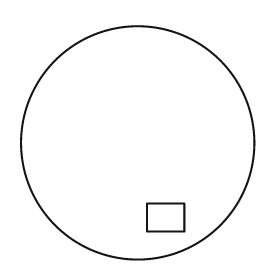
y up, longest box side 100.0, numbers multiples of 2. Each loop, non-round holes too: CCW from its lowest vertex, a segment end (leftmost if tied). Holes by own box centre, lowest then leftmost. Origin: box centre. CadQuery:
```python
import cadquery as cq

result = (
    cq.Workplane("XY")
    .moveTo(0.0, 0.0)
    .circle(50.0)
    .moveTo(4.0, -38.0)
    .lineTo(20.0, -38.0)
    .lineTo(20.0, -26.0)
    .lineTo(4.0, -26.0)
    .close()
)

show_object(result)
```